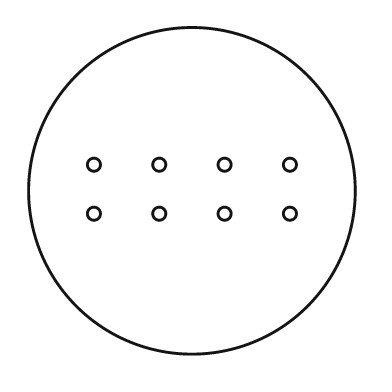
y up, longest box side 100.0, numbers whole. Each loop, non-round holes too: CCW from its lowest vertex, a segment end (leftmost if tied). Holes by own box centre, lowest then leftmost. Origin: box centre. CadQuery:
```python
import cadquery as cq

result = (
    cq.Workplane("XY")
    .moveTo(0.0, 0.0)
    .circle(50.0)
    .moveTo(-30.0, -7.0)
    .circle(2.0)
    .moveTo(-10.0, -7.0)
    .circle(2.0)
    .moveTo(10.0, -7.0)
    .circle(2.0)
    .moveTo(30.0, -7.0)
    .circle(2.0)
    .moveTo(-30.0, 8.0)
    .circle(2.0)
    .moveTo(-10.0, 8.0)
    .circle(2.0)
    .moveTo(10.0, 8.0)
    .circle(2.0)
    .moveTo(30.0, 8.0)
    .circle(2.0)
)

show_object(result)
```